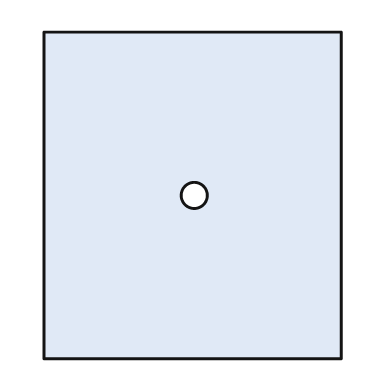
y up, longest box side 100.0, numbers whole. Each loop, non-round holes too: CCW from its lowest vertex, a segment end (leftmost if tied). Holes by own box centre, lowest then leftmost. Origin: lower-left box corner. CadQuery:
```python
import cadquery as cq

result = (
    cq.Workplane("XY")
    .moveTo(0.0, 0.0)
    .lineTo(91.0, 0.0)
    .lineTo(91.0, 100.0)
    .lineTo(0.0, 100.0)
    .close()
    .moveTo(46.0, 50.0)
    .circle(4.0)
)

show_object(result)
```